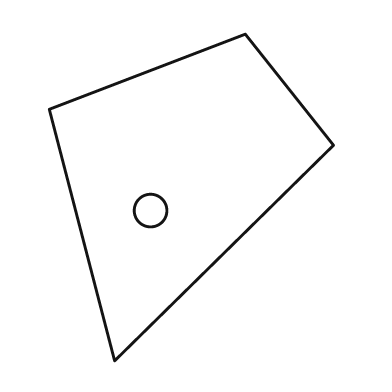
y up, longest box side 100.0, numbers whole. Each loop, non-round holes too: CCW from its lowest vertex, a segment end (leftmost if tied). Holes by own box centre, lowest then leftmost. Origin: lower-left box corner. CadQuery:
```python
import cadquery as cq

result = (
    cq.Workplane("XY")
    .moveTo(20.0, 0.0)
    .lineTo(87.0, 66.0)
    .lineTo(60.0, 100.0)
    .lineTo(0.0, 77.0)
    .close()
    .moveTo(31.0, 46.0)
    .circle(5.0)
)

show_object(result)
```